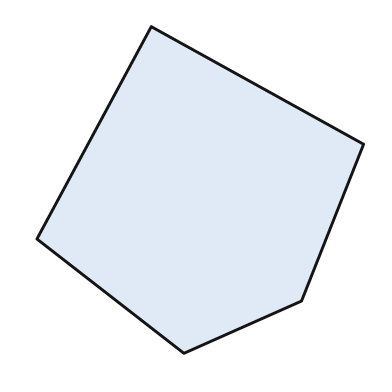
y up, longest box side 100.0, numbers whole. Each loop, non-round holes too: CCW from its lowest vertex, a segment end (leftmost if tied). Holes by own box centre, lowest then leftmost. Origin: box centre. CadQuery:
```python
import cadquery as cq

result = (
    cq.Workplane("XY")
    .moveTo(-5.0, -50.0)
    .lineTo(31.0, -34.0)
    .lineTo(50.0, 14.0)
    .lineTo(-15.0, 50.0)
    .lineTo(-50.0, -15.0)
    .close()
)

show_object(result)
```